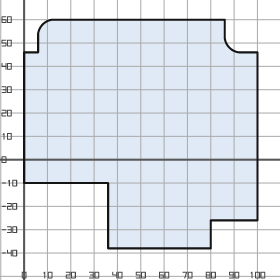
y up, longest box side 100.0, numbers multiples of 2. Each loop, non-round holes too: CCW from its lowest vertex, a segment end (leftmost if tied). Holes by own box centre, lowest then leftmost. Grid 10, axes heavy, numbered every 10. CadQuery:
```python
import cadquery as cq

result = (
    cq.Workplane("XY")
    .moveTo(36.0, -38.0)
    .lineTo(80.0, -38.0)
    .lineTo(80.0, -26.0)
    .lineTo(100.0, -26.0)
    .lineTo(100.0, 46.0)
    .lineTo(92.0, 46.0)
    .threePointArc((88.0, 48.0), (86.0, 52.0))
    .lineTo(86.0, 60.0)
    .lineTo(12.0, 60.0)
    .threePointArc((8.0, 58.0), (6.0, 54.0))
    .lineTo(6.0, 46.0)
    .lineTo(0.0, 46.0)
    .lineTo(0.0, -10.0)
    .lineTo(36.0, -10.0)
    .close()
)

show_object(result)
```